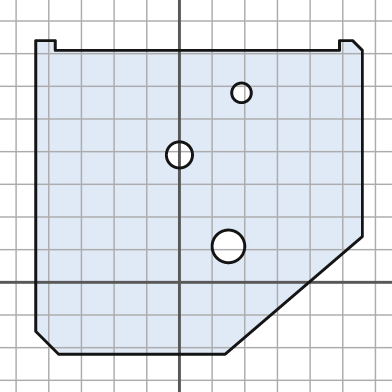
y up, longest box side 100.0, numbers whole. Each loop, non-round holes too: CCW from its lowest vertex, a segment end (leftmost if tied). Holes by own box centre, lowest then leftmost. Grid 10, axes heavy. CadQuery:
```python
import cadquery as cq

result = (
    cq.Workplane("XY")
    .moveTo(-37.0, -22.0)
    .lineTo(14.0, -22.0)
    .lineTo(56.0, 14.0)
    .lineTo(56.0, 71.0)
    .lineTo(53.0, 74.0)
    .lineTo(49.0, 74.0)
    .lineTo(49.0, 71.0)
    .lineTo(-38.0, 71.0)
    .lineTo(-38.0, 74.0)
    .lineTo(-44.0, 74.0)
    .lineTo(-44.0, -15.0)
    .close()
    .moveTo(15.0, 11.0)
    .circle(5.0)
    .moveTo(0.0, 39.0)
    .circle(4.0)
    .moveTo(19.0, 58.0)
    .circle(3.0)
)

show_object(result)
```